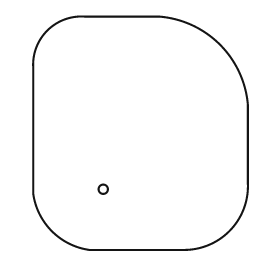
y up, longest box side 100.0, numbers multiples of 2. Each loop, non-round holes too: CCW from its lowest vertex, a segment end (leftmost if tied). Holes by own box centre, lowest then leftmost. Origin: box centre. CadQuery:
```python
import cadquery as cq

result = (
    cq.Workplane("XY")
    .moveTo(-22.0, -50.0)
    .lineTo(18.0, -50.0)
    .threePointArc((38.0, -42.0), (46.0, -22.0))
    .lineTo(46.0, 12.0)
    .threePointArc((34.0, 38.0), (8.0, 50.0))
    .lineTo(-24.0, 50.0)
    .threePointArc((-40.0, 44.0), (-46.0, 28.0))
    .lineTo(-46.0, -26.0)
    .threePointArc((-38.0, -42.0), (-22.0, -50.0))
    .close()
    .moveTo(-16.0, -24.0)
    .circle(2.0)
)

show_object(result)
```